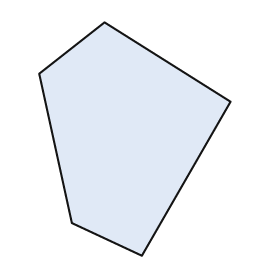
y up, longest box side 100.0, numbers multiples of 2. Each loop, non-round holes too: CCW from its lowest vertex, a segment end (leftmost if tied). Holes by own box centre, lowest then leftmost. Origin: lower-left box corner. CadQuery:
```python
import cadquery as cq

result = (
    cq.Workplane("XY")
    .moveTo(44.0, 0.0)
    .lineTo(82.0, 66.0)
    .lineTo(28.0, 100.0)
    .lineTo(0.0, 78.0)
    .lineTo(14.0, 14.0)
    .close()
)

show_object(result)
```